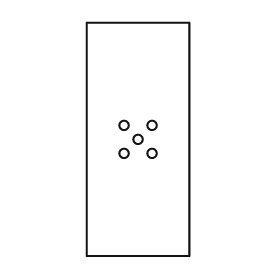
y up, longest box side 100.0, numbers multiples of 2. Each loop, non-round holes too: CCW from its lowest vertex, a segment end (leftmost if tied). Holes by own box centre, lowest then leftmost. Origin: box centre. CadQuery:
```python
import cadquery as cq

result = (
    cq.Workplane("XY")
    .moveTo(-22.0, -50.0)
    .lineTo(22.0, -50.0)
    .lineTo(22.0, 50.0)
    .lineTo(-22.0, 50.0)
    .close()
    .moveTo(-6.0, -6.0)
    .circle(2.0)
    .moveTo(6.0, -6.0)
    .circle(2.0)
    .moveTo(0.0, 0.0)
    .circle(2.0)
    .moveTo(-6.0, 6.0)
    .circle(2.0)
    .moveTo(6.0, 6.0)
    .circle(2.0)
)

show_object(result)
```